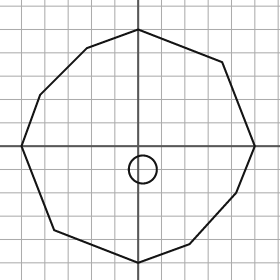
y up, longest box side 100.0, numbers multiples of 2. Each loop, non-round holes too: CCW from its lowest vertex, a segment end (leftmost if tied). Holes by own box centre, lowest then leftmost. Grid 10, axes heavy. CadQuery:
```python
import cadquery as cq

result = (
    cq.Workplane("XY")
    .moveTo(0.0, -50.0)
    .lineTo(22.0, -42.0)
    .lineTo(42.0, -20.0)
    .lineTo(50.0, 0.0)
    .lineTo(36.0, 36.0)
    .lineTo(0.0, 50.0)
    .lineTo(-22.0, 42.0)
    .lineTo(-42.0, 22.0)
    .lineTo(-50.0, 0.0)
    .lineTo(-36.0, -36.0)
    .close()
    .moveTo(2.0, -10.0)
    .circle(6.0)
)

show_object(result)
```